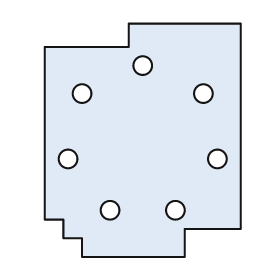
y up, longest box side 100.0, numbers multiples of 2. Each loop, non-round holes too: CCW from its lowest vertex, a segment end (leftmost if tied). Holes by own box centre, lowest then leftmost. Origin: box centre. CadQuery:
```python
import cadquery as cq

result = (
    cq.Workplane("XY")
    .moveTo(-26.0, -50.0)
    .lineTo(18.0, -50.0)
    .lineTo(18.0, -38.0)
    .lineTo(42.0, -38.0)
    .lineTo(42.0, 50.0)
    .lineTo(-6.0, 50.0)
    .lineTo(-6.0, 40.0)
    .lineTo(-42.0, 40.0)
    .lineTo(-42.0, -34.0)
    .lineTo(-34.0, -34.0)
    .lineTo(-34.0, -42.0)
    .lineTo(-26.0, -42.0)
    .close()
    .moveTo(-14.0, -30.0)
    .circle(4.0)
    .moveTo(14.0, -30.0)
    .circle(4.0)
    .moveTo(-32.0, -8.0)
    .circle(4.0)
    .moveTo(32.0, -8.0)
    .circle(4.0)
    .moveTo(-26.0, 20.0)
    .circle(4.0)
    .moveTo(26.0, 20.0)
    .circle(4.0)
    .moveTo(0.0, 32.0)
    .circle(4.0)
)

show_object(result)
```